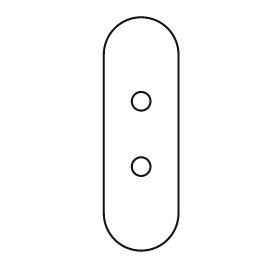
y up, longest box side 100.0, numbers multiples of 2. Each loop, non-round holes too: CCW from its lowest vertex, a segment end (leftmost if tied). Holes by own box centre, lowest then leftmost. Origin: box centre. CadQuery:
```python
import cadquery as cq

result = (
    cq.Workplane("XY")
    .moveTo(-16.0, -34.0)
    .threePointArc((0.0, -50.0), (16.0, -34.0))
    .lineTo(16.0, 34.0)
    .threePointArc((0.0, 50.0), (-16.0, 34.0))
    .close()
    .moveTo(0.0, -14.0)
    .circle(4.0)
    .moveTo(0.0, 14.0)
    .circle(4.0)
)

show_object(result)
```